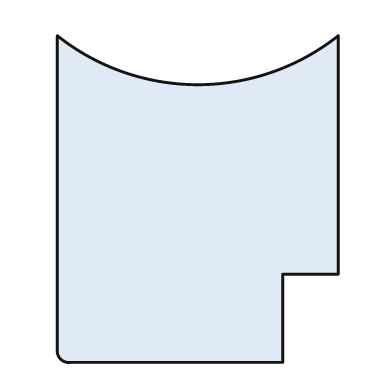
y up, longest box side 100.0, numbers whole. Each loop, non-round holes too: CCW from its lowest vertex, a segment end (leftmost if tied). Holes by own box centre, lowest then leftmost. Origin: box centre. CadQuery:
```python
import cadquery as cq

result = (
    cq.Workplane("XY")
    .moveTo(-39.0, -50.0)
    .lineTo(26.0, -50.0)
    .lineTo(26.0, -23.0)
    .lineTo(43.0, -23.0)
    .lineTo(43.0, 50.0)
    .threePointArc((0.0, 35.0), (-43.0, 50.0))
    .lineTo(-43.0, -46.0)
    .threePointArc((-42.0, -49.0), (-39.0, -50.0))
    .close()
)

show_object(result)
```